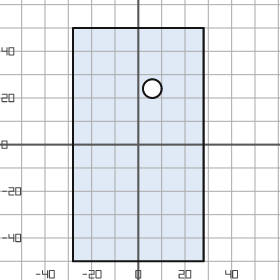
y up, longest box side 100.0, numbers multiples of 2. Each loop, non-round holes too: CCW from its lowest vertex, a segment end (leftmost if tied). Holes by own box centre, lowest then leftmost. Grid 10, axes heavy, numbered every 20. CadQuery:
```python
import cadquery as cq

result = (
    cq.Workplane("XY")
    .moveTo(-28.0, -50.0)
    .lineTo(28.0, -50.0)
    .lineTo(28.0, 50.0)
    .lineTo(-28.0, 50.0)
    .close()
    .moveTo(6.0, 24.0)
    .circle(4.0)
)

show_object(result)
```